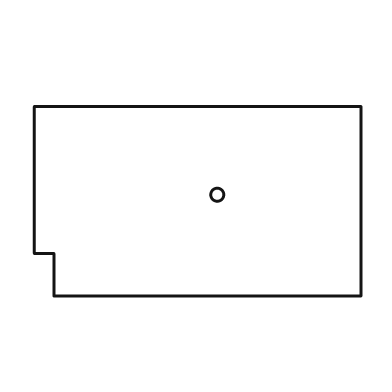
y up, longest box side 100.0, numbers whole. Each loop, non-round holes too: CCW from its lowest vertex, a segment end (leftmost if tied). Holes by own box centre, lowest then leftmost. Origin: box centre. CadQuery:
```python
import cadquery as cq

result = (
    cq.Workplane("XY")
    .moveTo(-44.0, -29.0)
    .lineTo(50.0, -29.0)
    .lineTo(50.0, 29.0)
    .lineTo(-50.0, 29.0)
    .lineTo(-50.0, -16.0)
    .lineTo(-44.0, -16.0)
    .close()
    .moveTo(6.0, 2.0)
    .circle(2.0)
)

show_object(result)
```